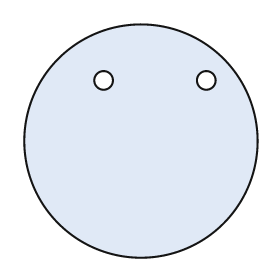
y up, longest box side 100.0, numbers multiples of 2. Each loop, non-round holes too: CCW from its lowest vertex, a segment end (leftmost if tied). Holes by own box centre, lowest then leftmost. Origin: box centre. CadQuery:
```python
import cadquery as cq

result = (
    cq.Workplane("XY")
    .moveTo(0.0, 0.0)
    .circle(50.0)
    .moveTo(-16.0, 26.0)
    .circle(4.0)
    .moveTo(28.0, 26.0)
    .circle(4.0)
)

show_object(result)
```